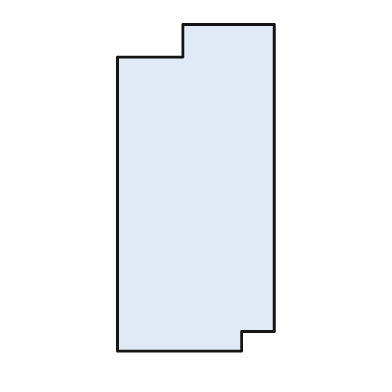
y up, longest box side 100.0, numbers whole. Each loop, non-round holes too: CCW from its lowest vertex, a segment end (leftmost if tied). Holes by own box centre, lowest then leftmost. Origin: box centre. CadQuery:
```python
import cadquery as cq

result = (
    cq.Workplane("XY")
    .moveTo(-24.0, -50.0)
    .lineTo(14.0, -50.0)
    .lineTo(14.0, -44.0)
    .lineTo(24.0, -44.0)
    .lineTo(24.0, 50.0)
    .lineTo(-4.0, 50.0)
    .lineTo(-4.0, 40.0)
    .lineTo(-24.0, 40.0)
    .close()
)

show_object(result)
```